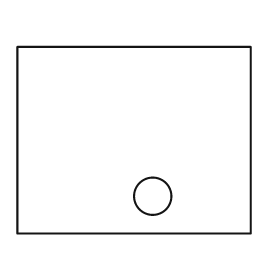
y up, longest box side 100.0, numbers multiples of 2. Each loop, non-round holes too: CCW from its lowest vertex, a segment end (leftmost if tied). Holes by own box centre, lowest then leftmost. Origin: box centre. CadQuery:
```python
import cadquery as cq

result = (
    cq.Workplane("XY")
    .moveTo(-50.0, -40.0)
    .lineTo(50.0, -40.0)
    .lineTo(50.0, 40.0)
    .lineTo(-50.0, 40.0)
    .close()
    .moveTo(8.0, -24.0)
    .circle(8.0)
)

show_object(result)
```